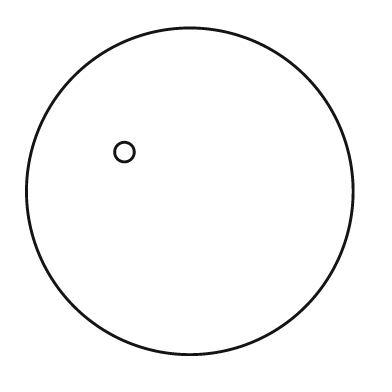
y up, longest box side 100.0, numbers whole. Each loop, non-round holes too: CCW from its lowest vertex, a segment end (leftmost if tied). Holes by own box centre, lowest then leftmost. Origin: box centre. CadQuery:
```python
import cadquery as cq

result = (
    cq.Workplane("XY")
    .moveTo(0.0, 0.0)
    .circle(50.0)
    .moveTo(-20.0, 12.0)
    .circle(3.0)
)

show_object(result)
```